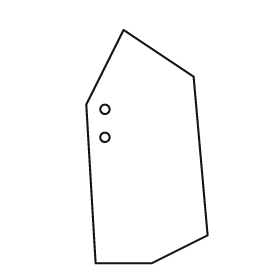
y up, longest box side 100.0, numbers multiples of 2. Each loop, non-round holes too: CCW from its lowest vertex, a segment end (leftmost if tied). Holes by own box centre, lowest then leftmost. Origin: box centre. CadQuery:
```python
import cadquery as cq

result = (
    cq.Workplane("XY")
    .moveTo(-22.0, -50.0)
    .lineTo(2.0, -50.0)
    .lineTo(26.0, -38.0)
    .lineTo(20.0, 30.0)
    .lineTo(-10.0, 50.0)
    .lineTo(-26.0, 18.0)
    .close()
    .moveTo(-18.0, 4.0)
    .circle(2.0)
    .moveTo(-18.0, 16.0)
    .circle(2.0)
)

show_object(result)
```